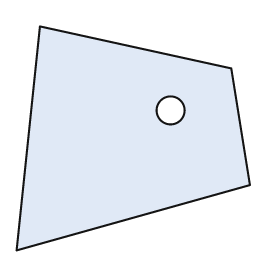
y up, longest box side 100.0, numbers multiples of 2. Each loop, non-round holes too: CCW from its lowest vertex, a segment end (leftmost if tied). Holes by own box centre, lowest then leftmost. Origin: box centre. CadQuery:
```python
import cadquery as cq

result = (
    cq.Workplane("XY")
    .moveTo(-50.0, -48.0)
    .lineTo(50.0, -20.0)
    .lineTo(42.0, 30.0)
    .lineTo(-40.0, 48.0)
    .close()
    .moveTo(16.0, 12.0)
    .circle(6.0)
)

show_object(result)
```